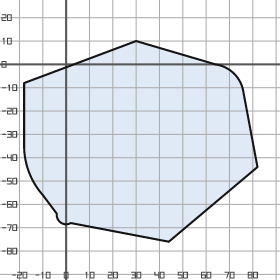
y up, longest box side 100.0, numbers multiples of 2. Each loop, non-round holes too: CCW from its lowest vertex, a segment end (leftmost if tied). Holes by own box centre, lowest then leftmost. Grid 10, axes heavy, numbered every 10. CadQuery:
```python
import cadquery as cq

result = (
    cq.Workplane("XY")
    .moveTo(44.0, -76.0)
    .lineTo(82.0, -44.0)
    .lineTo(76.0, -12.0)
    .threePointArc((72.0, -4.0), (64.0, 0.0))
    .lineTo(30.0, 10.0)
    .lineTo(-18.0, -8.0)
    .lineTo(-18.0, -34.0)
    .threePointArc((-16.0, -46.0), (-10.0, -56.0))
    .lineTo(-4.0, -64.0)
    .threePointArc((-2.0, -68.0), (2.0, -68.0))
    .close()
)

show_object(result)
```